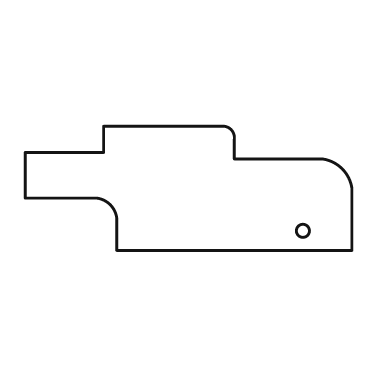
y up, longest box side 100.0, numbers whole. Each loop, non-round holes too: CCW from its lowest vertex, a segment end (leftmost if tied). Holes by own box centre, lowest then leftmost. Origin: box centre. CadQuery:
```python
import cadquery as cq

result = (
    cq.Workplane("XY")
    .moveTo(-22.0, -19.0)
    .lineTo(50.0, -19.0)
    .lineTo(50.0, 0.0)
    .threePointArc((47.0, 6.0), (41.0, 9.0))
    .lineTo(14.0, 9.0)
    .lineTo(14.0, 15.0)
    .threePointArc((13.0, 18.0), (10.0, 19.0))
    .lineTo(-26.0, 19.0)
    .lineTo(-26.0, 11.0)
    .lineTo(-50.0, 11.0)
    .lineTo(-50.0, -3.0)
    .lineTo(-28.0, -3.0)
    .threePointArc((-24.0, -5.0), (-22.0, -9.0))
    .close()
    .moveTo(35.0, -13.0)
    .circle(2.0)
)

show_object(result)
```